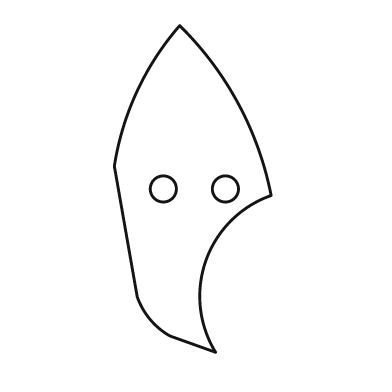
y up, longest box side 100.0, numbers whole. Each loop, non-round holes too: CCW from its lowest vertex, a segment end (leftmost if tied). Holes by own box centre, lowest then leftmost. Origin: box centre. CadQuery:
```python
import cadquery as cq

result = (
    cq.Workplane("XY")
    .moveTo(7.0, -50.0)
    .threePointArc((4.0, -22.0), (24.0, -2.0))
    .threePointArc((14.0, 26.0), (-4.0, 50.0))
    .threePointArc((-17.0, 30.0), (-24.0, 7.0))
    .lineTo(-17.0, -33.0)
    .threePointArc((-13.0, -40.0), (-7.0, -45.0))
    .close()
    .moveTo(-9.0, 0.0)
    .circle(4.0)
    .moveTo(10.0, 0.0)
    .circle(4.0)
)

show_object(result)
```